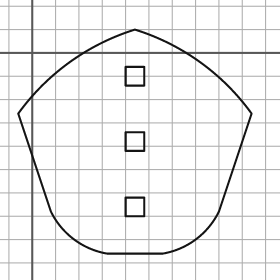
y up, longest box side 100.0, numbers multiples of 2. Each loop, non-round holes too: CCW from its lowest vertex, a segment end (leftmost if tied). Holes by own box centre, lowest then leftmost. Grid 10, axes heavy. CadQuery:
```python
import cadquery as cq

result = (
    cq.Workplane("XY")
    .moveTo(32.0, -86.0)
    .lineTo(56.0, -86.0)
    .threePointArc((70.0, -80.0), (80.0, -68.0))
    .lineTo(94.0, -26.0)
    .threePointArc((72.0, -4.0), (44.0, 10.0))
    .threePointArc((16.0, -4.0), (-6.0, -26.0))
    .lineTo(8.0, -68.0)
    .threePointArc((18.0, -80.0), (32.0, -86.0))
    .close()
    .moveTo(40.0, -70.0)
    .lineTo(48.0, -70.0)
    .lineTo(48.0, -62.0)
    .lineTo(40.0, -62.0)
    .close()
    .moveTo(40.0, -42.0)
    .lineTo(48.0, -42.0)
    .lineTo(48.0, -34.0)
    .lineTo(40.0, -34.0)
    .close()
    .moveTo(40.0, -14.0)
    .lineTo(48.0, -14.0)
    .lineTo(48.0, -6.0)
    .lineTo(40.0, -6.0)
    .close()
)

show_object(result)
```